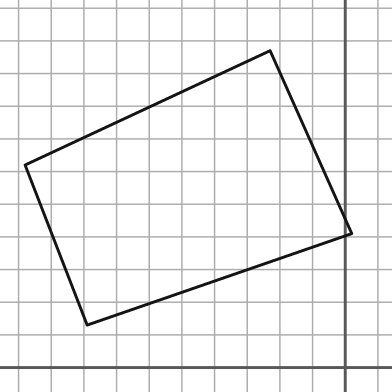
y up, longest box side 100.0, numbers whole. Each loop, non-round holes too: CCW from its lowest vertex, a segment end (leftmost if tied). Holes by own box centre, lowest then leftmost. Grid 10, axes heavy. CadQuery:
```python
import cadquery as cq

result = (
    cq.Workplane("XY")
    .moveTo(-79.0, 13.0)
    .lineTo(2.0, 41.0)
    .lineTo(-23.0, 97.0)
    .lineTo(-98.0, 62.0)
    .close()
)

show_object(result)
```